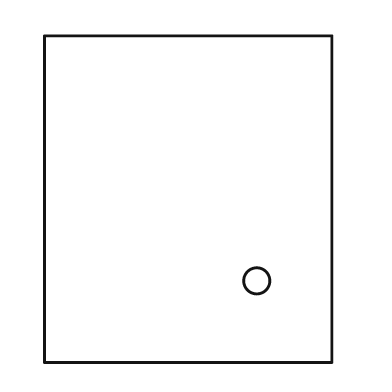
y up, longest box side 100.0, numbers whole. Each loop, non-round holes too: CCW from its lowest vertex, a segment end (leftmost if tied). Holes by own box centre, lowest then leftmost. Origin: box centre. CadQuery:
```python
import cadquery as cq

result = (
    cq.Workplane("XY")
    .moveTo(-44.0, -50.0)
    .lineTo(44.0, -50.0)
    .lineTo(44.0, 50.0)
    .lineTo(-44.0, 50.0)
    .close()
    .moveTo(21.0, -25.0)
    .circle(4.0)
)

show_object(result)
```